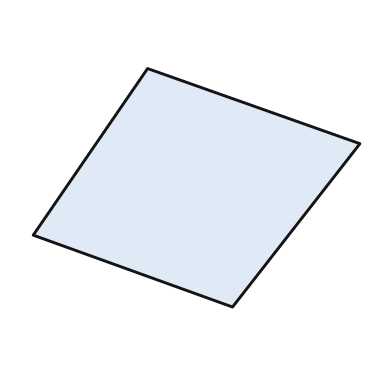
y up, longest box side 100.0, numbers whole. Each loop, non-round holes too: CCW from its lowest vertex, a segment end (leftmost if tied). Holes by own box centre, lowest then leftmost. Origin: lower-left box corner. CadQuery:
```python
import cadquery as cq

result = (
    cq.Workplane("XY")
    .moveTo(61.0, 0.0)
    .lineTo(100.0, 50.0)
    .lineTo(35.0, 73.0)
    .lineTo(0.0, 22.0)
    .close()
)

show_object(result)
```